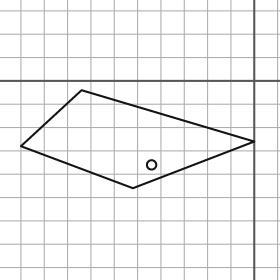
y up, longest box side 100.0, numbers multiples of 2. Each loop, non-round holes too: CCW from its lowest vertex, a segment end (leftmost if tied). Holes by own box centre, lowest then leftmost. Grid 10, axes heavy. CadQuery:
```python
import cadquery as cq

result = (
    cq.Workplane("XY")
    .moveTo(-52.0, -46.0)
    .lineTo(0.0, -26.0)
    .lineTo(-74.0, -4.0)
    .lineTo(-100.0, -28.0)
    .close()
    .moveTo(-44.0, -36.0)
    .circle(2.0)
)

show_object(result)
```